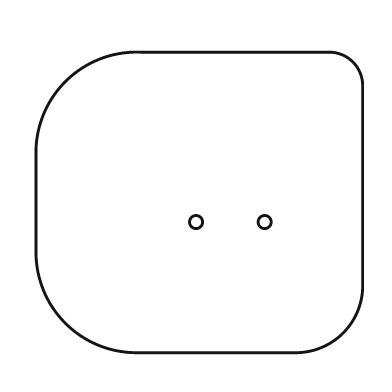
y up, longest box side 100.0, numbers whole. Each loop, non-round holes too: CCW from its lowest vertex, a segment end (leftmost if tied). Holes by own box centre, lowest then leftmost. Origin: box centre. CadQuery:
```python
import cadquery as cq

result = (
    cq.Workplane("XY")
    .moveTo(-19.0, -46.0)
    .lineTo(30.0, -46.0)
    .threePointArc((44.0, -40.0), (50.0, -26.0))
    .lineTo(50.0, 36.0)
    .threePointArc((47.0, 43.0), (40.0, 46.0))
    .lineTo(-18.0, 46.0)
    .threePointArc((-41.0, 37.0), (-50.0, 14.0))
    .lineTo(-50.0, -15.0)
    .threePointArc((-41.0, -37.0), (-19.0, -46.0))
    .close()
    .moveTo(-1.0, -6.0)
    .circle(2.0)
    .moveTo(20.0, -6.0)
    .circle(2.0)
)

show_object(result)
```